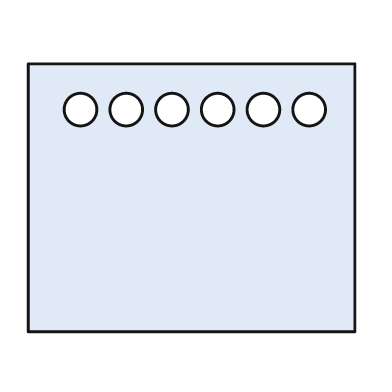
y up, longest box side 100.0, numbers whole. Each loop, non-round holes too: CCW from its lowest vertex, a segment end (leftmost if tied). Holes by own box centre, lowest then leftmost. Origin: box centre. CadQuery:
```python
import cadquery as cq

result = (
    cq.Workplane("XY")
    .moveTo(-50.0, -41.0)
    .lineTo(50.0, -41.0)
    .lineTo(50.0, 41.0)
    .lineTo(-50.0, 41.0)
    .close()
    .moveTo(-34.0, 27.0)
    .circle(5.0)
    .moveTo(-20.0, 27.0)
    .circle(5.0)
    .moveTo(-6.0, 27.0)
    .circle(5.0)
    .moveTo(8.0, 27.0)
    .circle(5.0)
    .moveTo(22.0, 27.0)
    .circle(5.0)
    .moveTo(36.0, 27.0)
    .circle(5.0)
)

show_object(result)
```